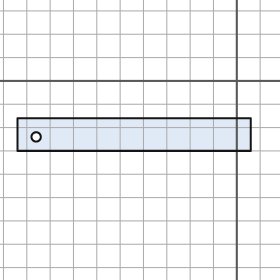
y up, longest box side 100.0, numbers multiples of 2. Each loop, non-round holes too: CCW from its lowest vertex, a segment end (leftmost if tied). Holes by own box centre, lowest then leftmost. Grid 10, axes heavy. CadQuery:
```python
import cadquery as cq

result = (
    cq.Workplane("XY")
    .moveTo(-94.0, -30.0)
    .lineTo(6.0, -30.0)
    .lineTo(6.0, -16.0)
    .lineTo(-94.0, -16.0)
    .close()
    .moveTo(-86.0, -24.0)
    .circle(2.0)
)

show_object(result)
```